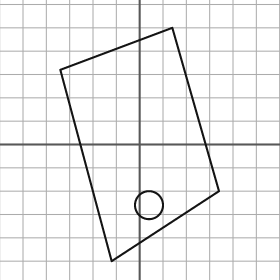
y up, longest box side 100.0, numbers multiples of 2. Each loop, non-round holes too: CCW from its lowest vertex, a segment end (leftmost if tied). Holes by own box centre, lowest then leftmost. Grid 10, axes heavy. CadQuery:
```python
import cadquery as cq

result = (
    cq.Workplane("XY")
    .moveTo(-12.0, -50.0)
    .lineTo(34.0, -20.0)
    .lineTo(14.0, 50.0)
    .lineTo(-34.0, 32.0)
    .close()
    .moveTo(4.0, -26.0)
    .circle(6.0)
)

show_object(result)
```